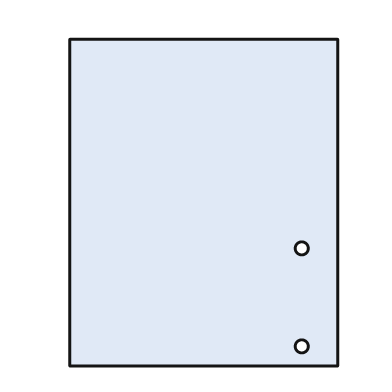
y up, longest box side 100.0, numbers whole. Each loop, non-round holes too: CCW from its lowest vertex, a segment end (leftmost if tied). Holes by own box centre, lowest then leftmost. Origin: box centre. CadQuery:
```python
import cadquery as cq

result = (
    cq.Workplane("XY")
    .moveTo(-41.0, -50.0)
    .lineTo(41.0, -50.0)
    .lineTo(41.0, 50.0)
    .lineTo(-41.0, 50.0)
    .close()
    .moveTo(30.0, -44.0)
    .circle(2.0)
    .moveTo(30.0, -14.0)
    .circle(2.0)
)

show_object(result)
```